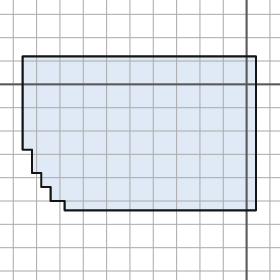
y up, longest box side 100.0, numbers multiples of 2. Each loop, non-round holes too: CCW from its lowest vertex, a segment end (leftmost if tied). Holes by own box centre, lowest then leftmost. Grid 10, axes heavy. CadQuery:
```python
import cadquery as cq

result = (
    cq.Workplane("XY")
    .moveTo(-78.0, -54.0)
    .lineTo(4.0, -54.0)
    .lineTo(4.0, 12.0)
    .lineTo(-96.0, 12.0)
    .lineTo(-96.0, -28.0)
    .lineTo(-92.0, -28.0)
    .lineTo(-92.0, -38.0)
    .lineTo(-88.0, -38.0)
    .lineTo(-88.0, -44.0)
    .lineTo(-84.0, -44.0)
    .lineTo(-84.0, -50.0)
    .lineTo(-78.0, -50.0)
    .close()
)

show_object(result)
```